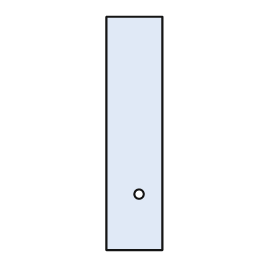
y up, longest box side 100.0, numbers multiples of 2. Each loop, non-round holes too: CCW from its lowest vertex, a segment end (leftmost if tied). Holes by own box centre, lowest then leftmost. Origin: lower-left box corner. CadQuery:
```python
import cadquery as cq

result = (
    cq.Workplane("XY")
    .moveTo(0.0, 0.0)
    .lineTo(24.0, 0.0)
    .lineTo(24.0, 100.0)
    .lineTo(0.0, 100.0)
    .close()
    .moveTo(14.0, 24.0)
    .circle(2.0)
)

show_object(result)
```